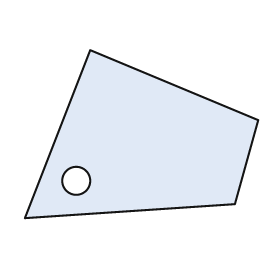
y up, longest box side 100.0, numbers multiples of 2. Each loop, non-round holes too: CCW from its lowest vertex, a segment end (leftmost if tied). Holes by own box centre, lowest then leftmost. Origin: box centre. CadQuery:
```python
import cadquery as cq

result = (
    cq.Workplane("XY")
    .moveTo(-50.0, -36.0)
    .lineTo(40.0, -30.0)
    .lineTo(50.0, 6.0)
    .lineTo(-22.0, 36.0)
    .close()
    .moveTo(-28.0, -20.0)
    .circle(6.0)
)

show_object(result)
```